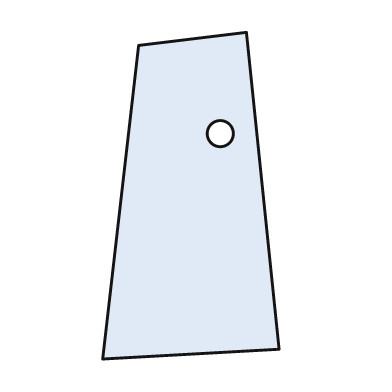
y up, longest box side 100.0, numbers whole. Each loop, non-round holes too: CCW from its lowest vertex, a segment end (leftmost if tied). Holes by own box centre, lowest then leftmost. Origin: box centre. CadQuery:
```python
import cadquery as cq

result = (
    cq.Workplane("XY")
    .moveTo(-27.0, -50.0)
    .lineTo(27.0, -47.0)
    .lineTo(17.0, 50.0)
    .lineTo(-16.0, 46.0)
    .close()
    .moveTo(9.0, 19.0)
    .circle(4.0)
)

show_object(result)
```